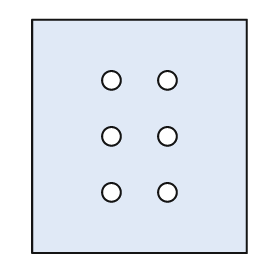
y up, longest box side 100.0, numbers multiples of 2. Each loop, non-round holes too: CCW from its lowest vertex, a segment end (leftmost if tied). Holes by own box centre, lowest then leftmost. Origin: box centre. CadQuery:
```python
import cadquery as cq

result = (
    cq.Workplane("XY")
    .moveTo(-46.0, -50.0)
    .lineTo(46.0, -50.0)
    .lineTo(46.0, 50.0)
    .lineTo(-46.0, 50.0)
    .close()
    .moveTo(-12.0, -24.0)
    .circle(4.0)
    .moveTo(12.0, -24.0)
    .circle(4.0)
    .moveTo(-12.0, 0.0)
    .circle(4.0)
    .moveTo(12.0, 0.0)
    .circle(4.0)
    .moveTo(-12.0, 24.0)
    .circle(4.0)
    .moveTo(12.0, 24.0)
    .circle(4.0)
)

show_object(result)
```